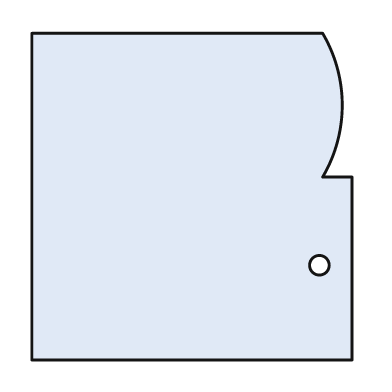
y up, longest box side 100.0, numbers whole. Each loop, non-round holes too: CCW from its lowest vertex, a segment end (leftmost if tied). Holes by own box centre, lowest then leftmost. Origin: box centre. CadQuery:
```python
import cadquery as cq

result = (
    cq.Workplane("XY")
    .moveTo(-49.0, -50.0)
    .lineTo(49.0, -50.0)
    .lineTo(49.0, 6.0)
    .lineTo(40.0, 6.0)
    .threePointArc((46.0, 28.0), (40.0, 50.0))
    .lineTo(-49.0, 50.0)
    .close()
    .moveTo(39.0, -21.0)
    .circle(3.0)
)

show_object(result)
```